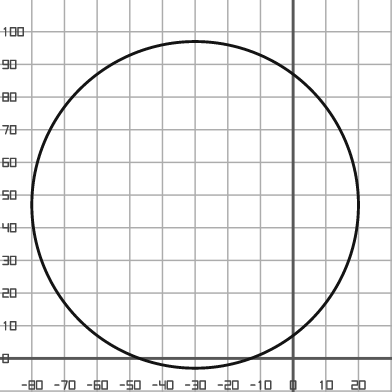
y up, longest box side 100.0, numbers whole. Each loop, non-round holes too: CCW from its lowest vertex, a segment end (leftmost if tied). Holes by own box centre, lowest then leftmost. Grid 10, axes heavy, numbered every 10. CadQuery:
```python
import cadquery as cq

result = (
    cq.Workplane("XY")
    .moveTo(-30.0, 47.0)
    .circle(50.0)
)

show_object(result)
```